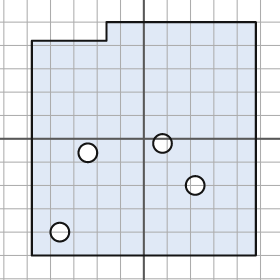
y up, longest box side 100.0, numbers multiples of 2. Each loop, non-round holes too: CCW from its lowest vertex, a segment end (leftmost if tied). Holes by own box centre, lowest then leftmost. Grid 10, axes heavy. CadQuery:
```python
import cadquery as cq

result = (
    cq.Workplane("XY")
    .moveTo(-48.0, -50.0)
    .lineTo(48.0, -50.0)
    .lineTo(48.0, 50.0)
    .lineTo(-16.0, 50.0)
    .lineTo(-16.0, 42.0)
    .lineTo(-48.0, 42.0)
    .close()
    .moveTo(-36.0, -40.0)
    .circle(4.0)
    .moveTo(22.0, -20.0)
    .circle(4.0)
    .moveTo(-24.0, -6.0)
    .circle(4.0)
    .moveTo(8.0, -2.0)
    .circle(4.0)
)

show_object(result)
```